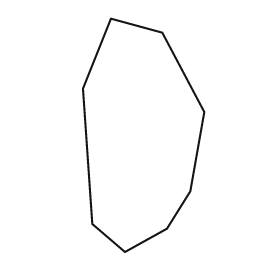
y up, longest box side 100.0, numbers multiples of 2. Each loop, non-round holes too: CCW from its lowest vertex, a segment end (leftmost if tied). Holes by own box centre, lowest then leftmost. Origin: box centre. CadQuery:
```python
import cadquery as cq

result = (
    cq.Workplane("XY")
    .moveTo(-8.0, -50.0)
    .lineTo(10.0, -40.0)
    .lineTo(20.0, -24.0)
    .lineTo(26.0, 10.0)
    .lineTo(8.0, 44.0)
    .lineTo(-14.0, 50.0)
    .lineTo(-26.0, 20.0)
    .lineTo(-22.0, -38.0)
    .close()
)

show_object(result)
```